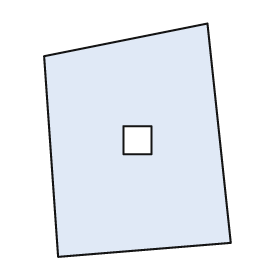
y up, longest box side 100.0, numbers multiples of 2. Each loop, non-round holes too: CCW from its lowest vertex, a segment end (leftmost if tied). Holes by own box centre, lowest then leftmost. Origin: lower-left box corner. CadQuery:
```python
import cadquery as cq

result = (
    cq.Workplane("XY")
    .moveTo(6.0, 0.0)
    .lineTo(80.0, 6.0)
    .lineTo(70.0, 100.0)
    .lineTo(0.0, 86.0)
    .close()
    .moveTo(34.0, 44.0)
    .lineTo(46.0, 44.0)
    .lineTo(46.0, 56.0)
    .lineTo(34.0, 56.0)
    .close()
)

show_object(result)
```